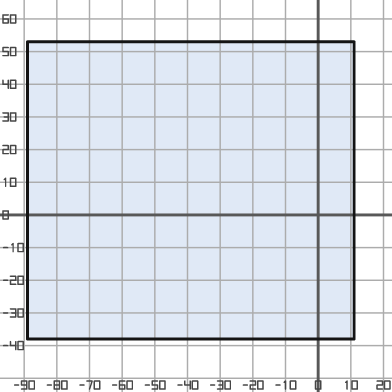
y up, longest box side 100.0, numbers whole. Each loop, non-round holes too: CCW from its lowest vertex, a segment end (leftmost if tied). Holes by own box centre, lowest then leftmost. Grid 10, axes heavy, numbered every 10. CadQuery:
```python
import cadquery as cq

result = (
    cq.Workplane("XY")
    .moveTo(-89.0, -38.0)
    .lineTo(11.0, -38.0)
    .lineTo(11.0, 53.0)
    .lineTo(-89.0, 53.0)
    .close()
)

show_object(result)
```